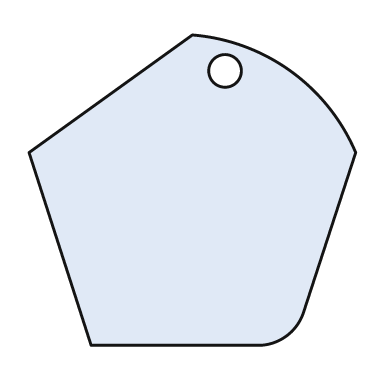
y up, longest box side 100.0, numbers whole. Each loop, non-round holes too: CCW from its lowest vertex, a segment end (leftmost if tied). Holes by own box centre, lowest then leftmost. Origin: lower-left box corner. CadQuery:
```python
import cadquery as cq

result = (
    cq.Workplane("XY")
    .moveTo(19.0, 0.0)
    .lineTo(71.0, 0.0)
    .threePointArc((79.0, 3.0), (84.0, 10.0))
    .lineTo(100.0, 59.0)
    .threePointArc((80.0, 84.0), (50.0, 95.0))
    .lineTo(0.0, 59.0)
    .close()
    .moveTo(60.0, 84.0)
    .circle(5.0)
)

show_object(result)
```